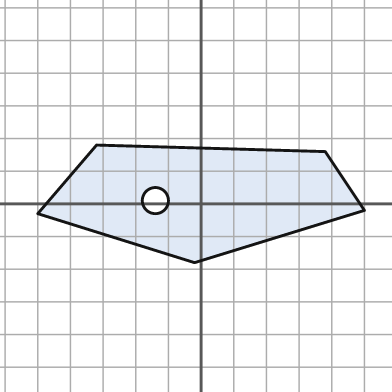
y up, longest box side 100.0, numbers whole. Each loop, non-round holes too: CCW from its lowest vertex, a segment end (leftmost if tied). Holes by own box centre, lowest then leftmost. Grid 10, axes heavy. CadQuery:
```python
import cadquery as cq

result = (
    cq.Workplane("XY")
    .moveTo(-2.0, -18.0)
    .lineTo(50.0, -2.0)
    .lineTo(38.0, 16.0)
    .lineTo(-32.0, 18.0)
    .lineTo(-50.0, -3.0)
    .close()
    .moveTo(-14.0, 1.0)
    .circle(4.0)
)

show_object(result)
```